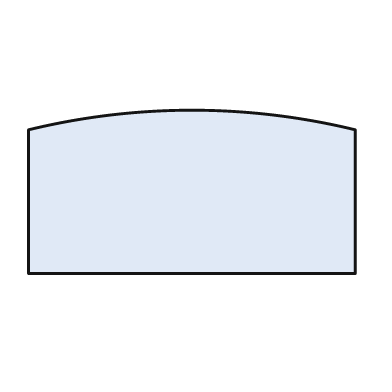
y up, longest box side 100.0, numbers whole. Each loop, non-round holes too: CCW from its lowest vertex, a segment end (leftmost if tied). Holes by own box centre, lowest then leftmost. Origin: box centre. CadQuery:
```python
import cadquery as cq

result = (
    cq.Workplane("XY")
    .moveTo(-50.0, -25.0)
    .lineTo(50.0, -25.0)
    .lineTo(50.0, 19.0)
    .threePointArc((0.0, 25.0), (-50.0, 19.0))
    .close()
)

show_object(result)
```